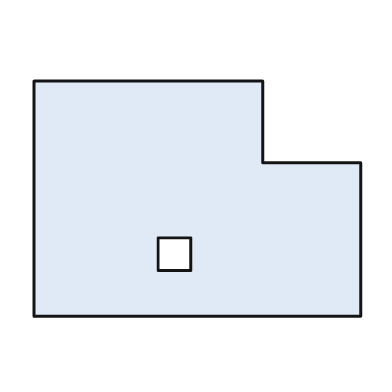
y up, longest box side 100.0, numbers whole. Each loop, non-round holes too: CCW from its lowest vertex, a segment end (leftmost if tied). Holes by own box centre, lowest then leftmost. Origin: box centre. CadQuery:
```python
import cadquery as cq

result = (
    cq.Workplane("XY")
    .moveTo(-50.0, -36.0)
    .lineTo(50.0, -36.0)
    .lineTo(50.0, 11.0)
    .lineTo(20.0, 11.0)
    .lineTo(20.0, 36.0)
    .lineTo(-50.0, 36.0)
    .close()
    .moveTo(-12.0, -22.0)
    .lineTo(-2.0, -22.0)
    .lineTo(-2.0, -12.0)
    .lineTo(-12.0, -12.0)
    .close()
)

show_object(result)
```